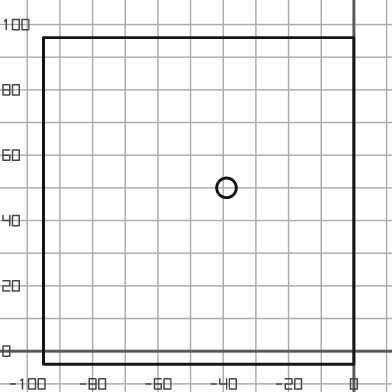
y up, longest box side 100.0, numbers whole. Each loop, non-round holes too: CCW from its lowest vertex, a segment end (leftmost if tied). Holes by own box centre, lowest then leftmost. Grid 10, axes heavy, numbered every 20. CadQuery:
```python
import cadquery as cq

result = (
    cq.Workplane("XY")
    .moveTo(-95.0, -4.0)
    .lineTo(0.0, -4.0)
    .lineTo(0.0, 96.0)
    .lineTo(-95.0, 96.0)
    .close()
    .moveTo(-39.0, 50.0)
    .circle(3.0)
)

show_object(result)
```